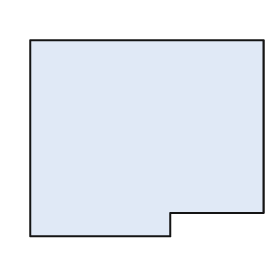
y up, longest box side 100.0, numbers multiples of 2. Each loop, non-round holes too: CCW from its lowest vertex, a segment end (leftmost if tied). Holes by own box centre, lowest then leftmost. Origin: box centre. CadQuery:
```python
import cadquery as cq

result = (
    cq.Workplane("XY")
    .moveTo(-50.0, -42.0)
    .lineTo(10.0, -42.0)
    .lineTo(10.0, -32.0)
    .lineTo(50.0, -32.0)
    .lineTo(50.0, 42.0)
    .lineTo(-50.0, 42.0)
    .close()
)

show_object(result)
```